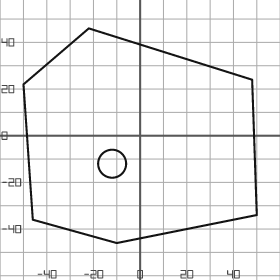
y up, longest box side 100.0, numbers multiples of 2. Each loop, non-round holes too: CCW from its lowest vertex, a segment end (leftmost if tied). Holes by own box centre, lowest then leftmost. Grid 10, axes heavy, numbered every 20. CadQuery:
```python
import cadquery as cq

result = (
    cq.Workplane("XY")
    .moveTo(-10.0, -46.0)
    .lineTo(50.0, -34.0)
    .lineTo(48.0, 24.0)
    .lineTo(-22.0, 46.0)
    .lineTo(-50.0, 22.0)
    .lineTo(-46.0, -36.0)
    .close()
    .moveTo(-12.0, -12.0)
    .circle(6.0)
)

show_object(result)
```